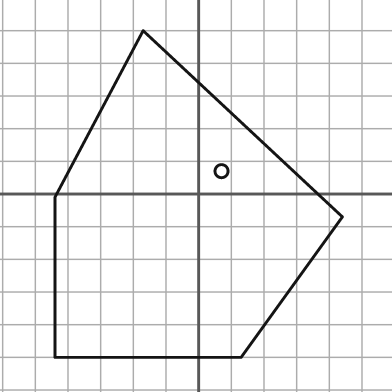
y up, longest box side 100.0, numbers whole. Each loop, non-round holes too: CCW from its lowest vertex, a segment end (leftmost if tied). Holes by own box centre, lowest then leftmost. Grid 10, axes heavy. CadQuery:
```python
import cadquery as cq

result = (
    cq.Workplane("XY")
    .moveTo(-44.0, -50.0)
    .lineTo(13.0, -50.0)
    .lineTo(44.0, -7.0)
    .lineTo(-17.0, 50.0)
    .lineTo(-44.0, -1.0)
    .close()
    .moveTo(7.0, 7.0)
    .circle(2.0)
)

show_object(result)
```